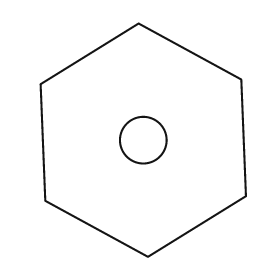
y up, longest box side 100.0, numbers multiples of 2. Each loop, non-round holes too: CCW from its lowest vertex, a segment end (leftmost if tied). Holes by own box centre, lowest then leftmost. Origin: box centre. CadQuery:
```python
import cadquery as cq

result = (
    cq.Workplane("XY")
    .moveTo(2.0, -50.0)
    .lineTo(44.0, -24.0)
    .lineTo(42.0, 26.0)
    .lineTo(-2.0, 50.0)
    .lineTo(-44.0, 24.0)
    .lineTo(-42.0, -26.0)
    .close()
    .moveTo(0.0, 0.0)
    .circle(10.0)
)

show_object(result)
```